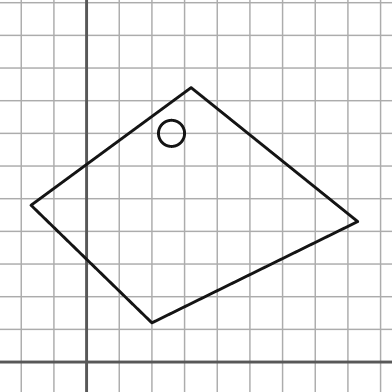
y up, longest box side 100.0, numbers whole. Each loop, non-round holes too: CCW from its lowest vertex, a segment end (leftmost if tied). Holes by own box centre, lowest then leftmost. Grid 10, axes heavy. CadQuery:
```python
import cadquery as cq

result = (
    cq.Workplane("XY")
    .moveTo(20.0, 12.0)
    .lineTo(83.0, 43.0)
    .lineTo(32.0, 84.0)
    .lineTo(-17.0, 48.0)
    .close()
    .moveTo(26.0, 70.0)
    .circle(4.0)
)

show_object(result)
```